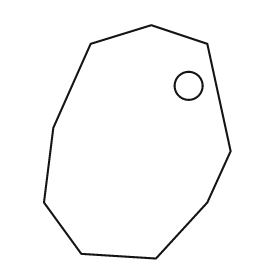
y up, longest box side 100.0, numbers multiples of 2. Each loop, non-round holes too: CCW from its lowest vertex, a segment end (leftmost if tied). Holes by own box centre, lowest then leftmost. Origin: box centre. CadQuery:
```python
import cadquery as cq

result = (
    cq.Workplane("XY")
    .moveTo(8.0, -50.0)
    .lineTo(30.0, -26.0)
    .lineTo(40.0, -4.0)
    .lineTo(30.0, 42.0)
    .lineTo(6.0, 50.0)
    .lineTo(-20.0, 42.0)
    .lineTo(-36.0, 6.0)
    .lineTo(-40.0, -26.0)
    .lineTo(-24.0, -48.0)
    .close()
    .moveTo(22.0, 24.0)
    .circle(6.0)
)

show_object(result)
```